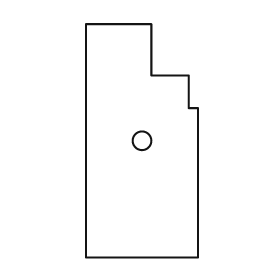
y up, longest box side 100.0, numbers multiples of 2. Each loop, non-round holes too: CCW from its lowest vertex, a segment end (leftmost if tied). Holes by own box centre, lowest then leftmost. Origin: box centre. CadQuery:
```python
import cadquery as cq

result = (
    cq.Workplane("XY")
    .moveTo(-24.0, -50.0)
    .lineTo(24.0, -50.0)
    .lineTo(24.0, 14.0)
    .lineTo(20.0, 14.0)
    .lineTo(20.0, 28.0)
    .lineTo(4.0, 28.0)
    .lineTo(4.0, 50.0)
    .lineTo(-24.0, 50.0)
    .close()
    .moveTo(0.0, 0.0)
    .circle(4.0)
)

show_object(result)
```